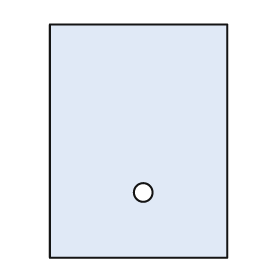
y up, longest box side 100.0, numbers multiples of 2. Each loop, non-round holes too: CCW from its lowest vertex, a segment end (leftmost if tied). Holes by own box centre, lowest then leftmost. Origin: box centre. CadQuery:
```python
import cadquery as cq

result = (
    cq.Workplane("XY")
    .moveTo(-38.0, -50.0)
    .lineTo(38.0, -50.0)
    .lineTo(38.0, 50.0)
    .lineTo(-38.0, 50.0)
    .close()
    .moveTo(2.0, -22.0)
    .circle(4.0)
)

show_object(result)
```